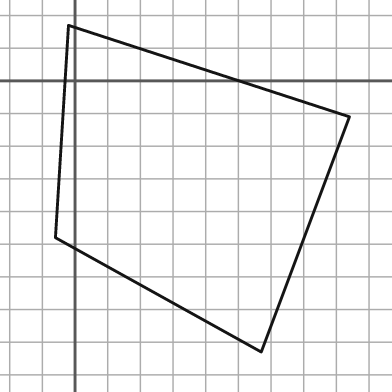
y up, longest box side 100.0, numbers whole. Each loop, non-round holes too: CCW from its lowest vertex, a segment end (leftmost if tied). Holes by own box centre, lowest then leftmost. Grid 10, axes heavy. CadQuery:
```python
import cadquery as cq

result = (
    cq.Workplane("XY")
    .moveTo(57.0, -83.0)
    .lineTo(84.0, -11.0)
    .lineTo(-2.0, 17.0)
    .lineTo(-6.0, -48.0)
    .close()
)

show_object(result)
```